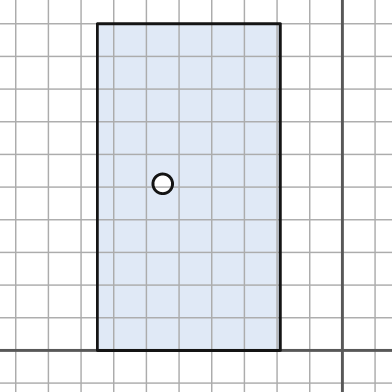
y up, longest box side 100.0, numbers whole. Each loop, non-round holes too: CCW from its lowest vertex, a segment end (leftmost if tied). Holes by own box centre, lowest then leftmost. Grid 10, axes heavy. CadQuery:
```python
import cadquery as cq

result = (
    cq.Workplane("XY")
    .moveTo(-75.0, 0.0)
    .lineTo(-19.0, 0.0)
    .lineTo(-19.0, 100.0)
    .lineTo(-75.0, 100.0)
    .close()
    .moveTo(-55.0, 51.0)
    .circle(3.0)
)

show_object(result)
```